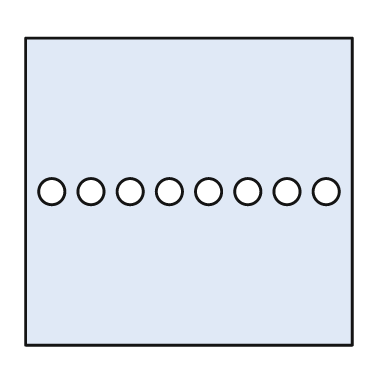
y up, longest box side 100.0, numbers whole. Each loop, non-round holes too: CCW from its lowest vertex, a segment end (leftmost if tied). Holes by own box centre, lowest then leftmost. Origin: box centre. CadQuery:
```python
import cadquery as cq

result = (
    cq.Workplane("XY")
    .moveTo(-50.0, -47.0)
    .lineTo(50.0, -47.0)
    .lineTo(50.0, 47.0)
    .lineTo(-50.0, 47.0)
    .close()
    .moveTo(-42.0, 0.0)
    .circle(4.0)
    .moveTo(-30.0, 0.0)
    .circle(4.0)
    .moveTo(-18.0, 0.0)
    .circle(4.0)
    .moveTo(-6.0, 0.0)
    .circle(4.0)
    .moveTo(6.0, 0.0)
    .circle(4.0)
    .moveTo(18.0, 0.0)
    .circle(4.0)
    .moveTo(30.0, 0.0)
    .circle(4.0)
    .moveTo(42.0, 0.0)
    .circle(4.0)
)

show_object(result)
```